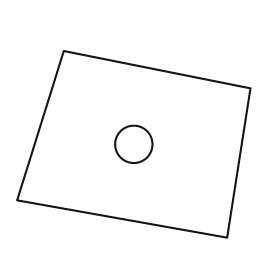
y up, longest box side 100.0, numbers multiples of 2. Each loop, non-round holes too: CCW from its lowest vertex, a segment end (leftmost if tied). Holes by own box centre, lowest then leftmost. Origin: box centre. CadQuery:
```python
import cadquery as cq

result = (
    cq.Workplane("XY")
    .moveTo(40.0, -40.0)
    .lineTo(50.0, 24.0)
    .lineTo(-30.0, 40.0)
    .lineTo(-50.0, -24.0)
    .close()
    .moveTo(0.0, 0.0)
    .circle(8.0)
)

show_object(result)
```